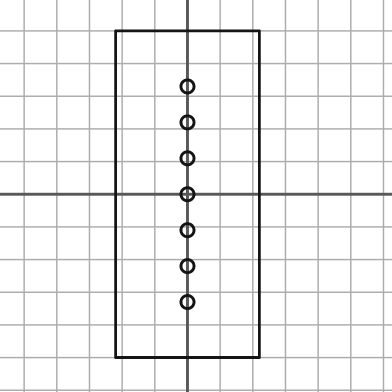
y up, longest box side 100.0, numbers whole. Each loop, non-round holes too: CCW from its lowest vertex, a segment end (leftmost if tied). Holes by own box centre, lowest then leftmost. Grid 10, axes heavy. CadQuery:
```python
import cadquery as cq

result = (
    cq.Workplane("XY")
    .moveTo(-22.0, -50.0)
    .lineTo(22.0, -50.0)
    .lineTo(22.0, 50.0)
    .lineTo(-22.0, 50.0)
    .close()
    .moveTo(0.0, -33.0)
    .circle(2.0)
    .moveTo(0.0, -22.0)
    .circle(2.0)
    .moveTo(0.0, -11.0)
    .circle(2.0)
    .moveTo(0.0, 0.0)
    .circle(2.0)
    .moveTo(0.0, 11.0)
    .circle(2.0)
    .moveTo(0.0, 22.0)
    .circle(2.0)
    .moveTo(0.0, 33.0)
    .circle(2.0)
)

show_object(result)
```